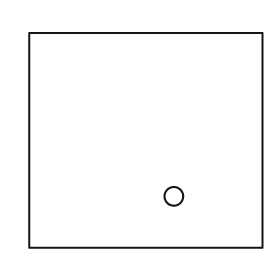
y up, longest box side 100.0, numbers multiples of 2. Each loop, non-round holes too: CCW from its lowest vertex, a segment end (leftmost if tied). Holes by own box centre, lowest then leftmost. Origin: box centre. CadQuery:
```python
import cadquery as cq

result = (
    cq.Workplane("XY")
    .moveTo(-50.0, -46.0)
    .lineTo(50.0, -46.0)
    .lineTo(50.0, 46.0)
    .lineTo(-50.0, 46.0)
    .close()
    .moveTo(12.0, -24.0)
    .circle(4.0)
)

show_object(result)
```